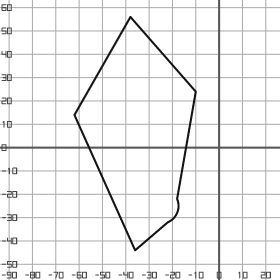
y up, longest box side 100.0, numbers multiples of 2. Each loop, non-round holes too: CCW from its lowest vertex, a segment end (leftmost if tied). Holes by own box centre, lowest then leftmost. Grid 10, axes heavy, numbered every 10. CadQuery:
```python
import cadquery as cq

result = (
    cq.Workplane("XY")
    .moveTo(-36.0, -44.0)
    .lineTo(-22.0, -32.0)
    .threePointArc((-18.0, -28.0), (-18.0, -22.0))
    .lineTo(-10.0, 24.0)
    .lineTo(-38.0, 56.0)
    .lineTo(-62.0, 14.0)
    .close()
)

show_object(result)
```